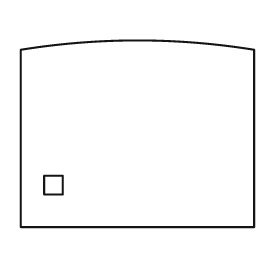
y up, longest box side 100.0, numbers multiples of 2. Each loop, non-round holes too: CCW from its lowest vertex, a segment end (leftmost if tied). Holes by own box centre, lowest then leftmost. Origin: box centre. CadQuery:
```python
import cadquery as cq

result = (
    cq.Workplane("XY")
    .moveTo(-50.0, -40.0)
    .lineTo(50.0, -40.0)
    .lineTo(50.0, 36.0)
    .threePointArc((0.0, 40.0), (-50.0, 36.0))
    .close()
    .moveTo(-40.0, -26.0)
    .lineTo(-32.0, -26.0)
    .lineTo(-32.0, -18.0)
    .lineTo(-40.0, -18.0)
    .close()
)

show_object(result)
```